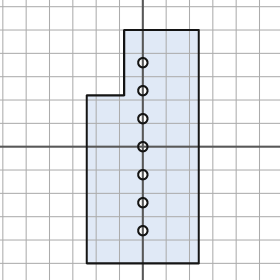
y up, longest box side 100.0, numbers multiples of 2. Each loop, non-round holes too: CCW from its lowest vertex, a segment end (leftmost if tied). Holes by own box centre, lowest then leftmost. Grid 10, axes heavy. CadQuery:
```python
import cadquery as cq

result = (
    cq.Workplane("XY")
    .moveTo(-24.0, -50.0)
    .lineTo(24.0, -50.0)
    .lineTo(24.0, 50.0)
    .lineTo(-8.0, 50.0)
    .lineTo(-8.0, 22.0)
    .lineTo(-24.0, 22.0)
    .close()
    .moveTo(0.0, -36.0)
    .circle(2.0)
    .moveTo(0.0, -24.0)
    .circle(2.0)
    .moveTo(0.0, -12.0)
    .circle(2.0)
    .moveTo(0.0, 0.0)
    .circle(2.0)
    .moveTo(0.0, 12.0)
    .circle(2.0)
    .moveTo(0.0, 24.0)
    .circle(2.0)
    .moveTo(0.0, 36.0)
    .circle(2.0)
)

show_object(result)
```